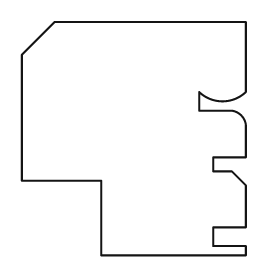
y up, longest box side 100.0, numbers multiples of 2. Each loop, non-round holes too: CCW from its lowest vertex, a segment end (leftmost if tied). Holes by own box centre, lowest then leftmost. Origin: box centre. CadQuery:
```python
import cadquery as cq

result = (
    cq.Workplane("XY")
    .moveTo(-14.0, -50.0)
    .lineTo(48.0, -50.0)
    .lineTo(48.0, -46.0)
    .lineTo(34.0, -46.0)
    .lineTo(34.0, -38.0)
    .lineTo(48.0, -38.0)
    .lineTo(48.0, -20.0)
    .lineTo(42.0, -14.0)
    .lineTo(34.0, -14.0)
    .lineTo(34.0, -8.0)
    .lineTo(48.0, -8.0)
    .lineTo(48.0, 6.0)
    .threePointArc((46.0, 10.0), (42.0, 12.0))
    .lineTo(28.0, 12.0)
    .lineTo(28.0, 20.0)
    .threePointArc((38.0, 16.0), (48.0, 20.0))
    .lineTo(48.0, 50.0)
    .lineTo(-34.0, 50.0)
    .lineTo(-48.0, 36.0)
    .lineTo(-48.0, -18.0)
    .lineTo(-14.0, -18.0)
    .close()
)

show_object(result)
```